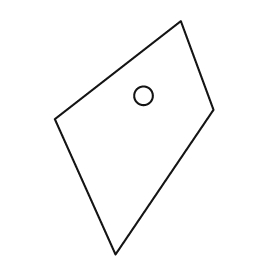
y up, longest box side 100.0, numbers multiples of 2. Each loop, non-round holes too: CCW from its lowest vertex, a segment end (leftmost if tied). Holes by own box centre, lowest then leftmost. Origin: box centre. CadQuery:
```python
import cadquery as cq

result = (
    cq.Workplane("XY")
    .moveTo(-8.0, -50.0)
    .lineTo(34.0, 12.0)
    .lineTo(20.0, 50.0)
    .lineTo(-34.0, 8.0)
    .close()
    .moveTo(4.0, 18.0)
    .circle(4.0)
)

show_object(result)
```